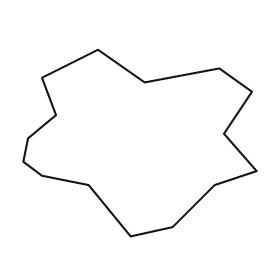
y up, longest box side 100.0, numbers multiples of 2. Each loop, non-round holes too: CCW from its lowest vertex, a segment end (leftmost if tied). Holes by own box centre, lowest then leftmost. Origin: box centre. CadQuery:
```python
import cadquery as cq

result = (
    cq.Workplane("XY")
    .moveTo(-4.0, -40.0)
    .lineTo(14.0, -36.0)
    .lineTo(32.0, -18.0)
    .lineTo(50.0, -12.0)
    .lineTo(36.0, 4.0)
    .lineTo(48.0, 22.0)
    .lineTo(34.0, 32.0)
    .lineTo(2.0, 26.0)
    .lineTo(-18.0, 40.0)
    .lineTo(-42.0, 28.0)
    .lineTo(-36.0, 12.0)
    .lineTo(-48.0, 2.0)
    .lineTo(-50.0, -8.0)
    .lineTo(-42.0, -14.0)
    .lineTo(-22.0, -18.0)
    .close()
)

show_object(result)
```